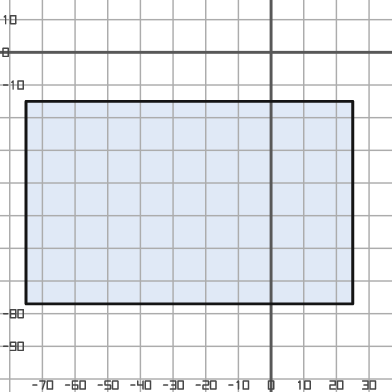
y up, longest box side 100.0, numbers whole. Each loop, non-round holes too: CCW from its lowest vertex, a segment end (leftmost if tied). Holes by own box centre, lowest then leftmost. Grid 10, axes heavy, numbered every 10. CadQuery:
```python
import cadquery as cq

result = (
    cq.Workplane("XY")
    .moveTo(-75.0, -77.0)
    .lineTo(25.0, -77.0)
    .lineTo(25.0, -15.0)
    .lineTo(-75.0, -15.0)
    .close()
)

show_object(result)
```